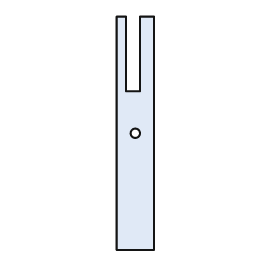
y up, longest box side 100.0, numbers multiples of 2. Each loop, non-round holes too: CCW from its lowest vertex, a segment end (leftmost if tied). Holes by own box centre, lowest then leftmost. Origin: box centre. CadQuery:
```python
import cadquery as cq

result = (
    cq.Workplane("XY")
    .moveTo(-8.0, -50.0)
    .lineTo(8.0, -50.0)
    .lineTo(8.0, 50.0)
    .lineTo(2.0, 50.0)
    .lineTo(2.0, 18.0)
    .lineTo(-4.0, 18.0)
    .lineTo(-4.0, 50.0)
    .lineTo(-8.0, 50.0)
    .close()
    .moveTo(0.0, 0.0)
    .circle(2.0)
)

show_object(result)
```